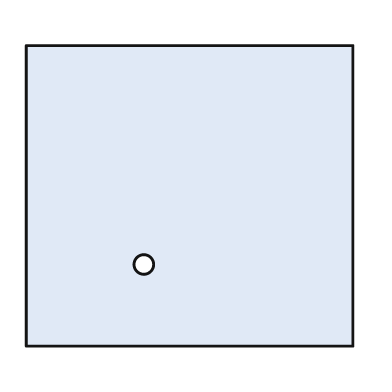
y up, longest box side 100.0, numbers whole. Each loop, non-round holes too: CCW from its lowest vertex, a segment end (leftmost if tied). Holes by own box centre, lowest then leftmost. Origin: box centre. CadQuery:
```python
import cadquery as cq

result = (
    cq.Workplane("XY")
    .moveTo(-50.0, -46.0)
    .lineTo(50.0, -46.0)
    .lineTo(50.0, 46.0)
    .lineTo(-50.0, 46.0)
    .close()
    .moveTo(-14.0, -21.0)
    .circle(3.0)
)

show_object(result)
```